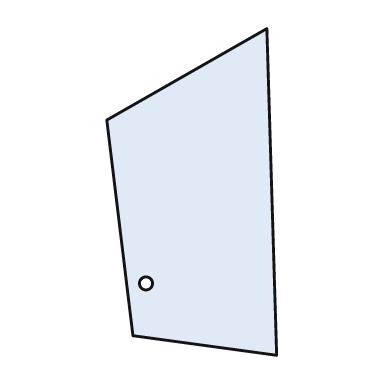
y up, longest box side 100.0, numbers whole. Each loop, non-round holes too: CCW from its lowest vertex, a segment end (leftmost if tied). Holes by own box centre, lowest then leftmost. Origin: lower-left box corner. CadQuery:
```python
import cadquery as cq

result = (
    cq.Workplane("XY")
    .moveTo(52.0, 0.0)
    .lineTo(49.0, 100.0)
    .lineTo(0.0, 72.0)
    .lineTo(8.0, 6.0)
    .close()
    .moveTo(12.0, 22.0)
    .circle(2.0)
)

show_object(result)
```